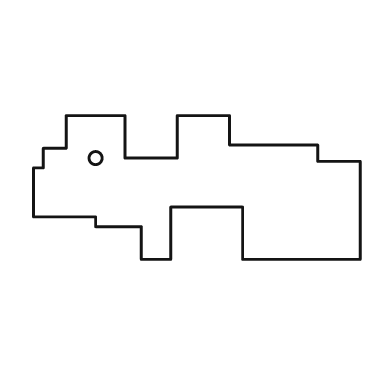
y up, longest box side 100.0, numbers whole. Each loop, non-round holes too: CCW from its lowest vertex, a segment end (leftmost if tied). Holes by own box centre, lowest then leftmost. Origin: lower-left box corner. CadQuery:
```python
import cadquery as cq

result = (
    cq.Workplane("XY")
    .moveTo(33.0, 0.0)
    .lineTo(42.0, 0.0)
    .lineTo(42.0, 16.0)
    .lineTo(64.0, 16.0)
    .lineTo(64.0, 0.0)
    .lineTo(100.0, 0.0)
    .lineTo(100.0, 30.0)
    .lineTo(87.0, 30.0)
    .lineTo(87.0, 35.0)
    .lineTo(60.0, 35.0)
    .lineTo(60.0, 44.0)
    .lineTo(44.0, 44.0)
    .lineTo(44.0, 31.0)
    .lineTo(28.0, 31.0)
    .lineTo(28.0, 44.0)
    .lineTo(10.0, 44.0)
    .lineTo(10.0, 34.0)
    .lineTo(3.0, 34.0)
    .lineTo(3.0, 28.0)
    .lineTo(0.0, 28.0)
    .lineTo(0.0, 13.0)
    .lineTo(19.0, 13.0)
    .lineTo(19.0, 10.0)
    .lineTo(33.0, 10.0)
    .close()
    .moveTo(19.0, 31.0)
    .circle(2.0)
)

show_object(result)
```